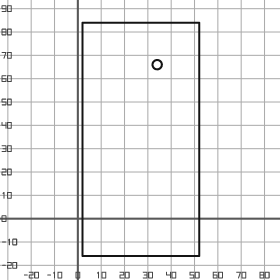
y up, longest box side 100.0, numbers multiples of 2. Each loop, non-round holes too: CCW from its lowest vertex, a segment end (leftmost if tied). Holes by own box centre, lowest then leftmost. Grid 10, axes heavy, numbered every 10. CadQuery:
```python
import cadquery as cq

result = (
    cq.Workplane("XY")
    .moveTo(2.0, -16.0)
    .lineTo(52.0, -16.0)
    .lineTo(52.0, 84.0)
    .lineTo(2.0, 84.0)
    .close()
    .moveTo(34.0, 66.0)
    .circle(2.0)
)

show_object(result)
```